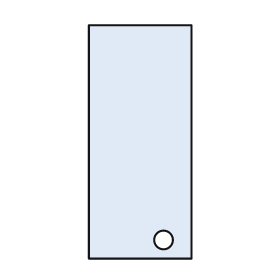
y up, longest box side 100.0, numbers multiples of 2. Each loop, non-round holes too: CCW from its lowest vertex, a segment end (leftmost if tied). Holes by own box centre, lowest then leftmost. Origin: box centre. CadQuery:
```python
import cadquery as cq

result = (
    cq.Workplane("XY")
    .moveTo(-22.0, -50.0)
    .lineTo(22.0, -50.0)
    .lineTo(22.0, 50.0)
    .lineTo(-22.0, 50.0)
    .close()
    .moveTo(10.0, -42.0)
    .circle(4.0)
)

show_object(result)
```